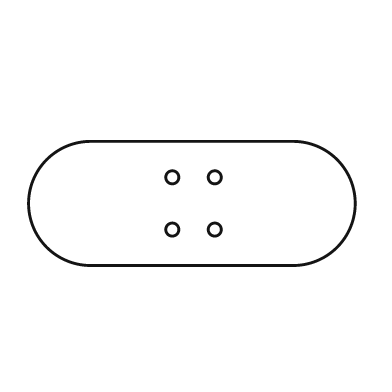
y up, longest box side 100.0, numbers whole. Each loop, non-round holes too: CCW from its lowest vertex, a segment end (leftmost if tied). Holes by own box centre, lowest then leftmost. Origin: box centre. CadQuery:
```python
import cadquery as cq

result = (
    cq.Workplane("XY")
    .moveTo(-31.0, -19.0)
    .lineTo(31.0, -19.0)
    .threePointArc((50.0, 0.0), (31.0, 19.0))
    .lineTo(-31.0, 19.0)
    .threePointArc((-50.0, 0.0), (-31.0, -19.0))
    .close()
    .moveTo(-6.0, -8.0)
    .circle(2.0)
    .moveTo(7.0, -8.0)
    .circle(2.0)
    .moveTo(-6.0, 8.0)
    .circle(2.0)
    .moveTo(7.0, 8.0)
    .circle(2.0)
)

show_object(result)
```